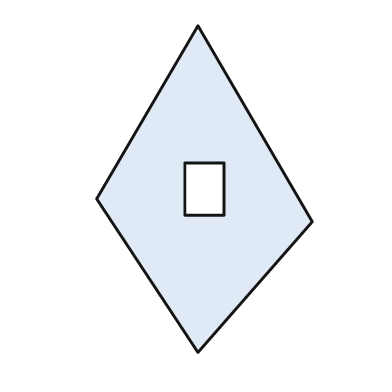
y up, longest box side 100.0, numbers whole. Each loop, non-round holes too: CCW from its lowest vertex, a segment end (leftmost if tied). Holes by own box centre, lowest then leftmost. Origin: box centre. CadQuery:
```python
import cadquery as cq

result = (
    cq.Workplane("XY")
    .moveTo(-2.0, -50.0)
    .lineTo(33.0, -10.0)
    .lineTo(-2.0, 50.0)
    .lineTo(-33.0, -3.0)
    .close()
    .moveTo(-6.0, -8.0)
    .lineTo(6.0, -8.0)
    .lineTo(6.0, 8.0)
    .lineTo(-6.0, 8.0)
    .close()
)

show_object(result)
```